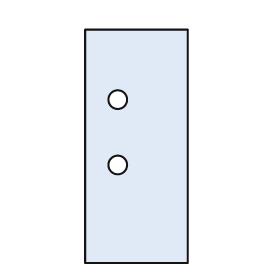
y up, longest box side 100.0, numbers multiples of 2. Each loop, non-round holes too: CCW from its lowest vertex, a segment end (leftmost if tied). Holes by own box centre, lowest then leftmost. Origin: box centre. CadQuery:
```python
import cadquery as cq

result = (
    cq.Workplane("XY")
    .moveTo(-22.0, -50.0)
    .lineTo(22.0, -50.0)
    .lineTo(22.0, 50.0)
    .lineTo(-22.0, 50.0)
    .close()
    .moveTo(-8.0, -8.0)
    .circle(4.0)
    .moveTo(-8.0, 20.0)
    .circle(4.0)
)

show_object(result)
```